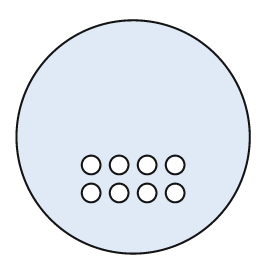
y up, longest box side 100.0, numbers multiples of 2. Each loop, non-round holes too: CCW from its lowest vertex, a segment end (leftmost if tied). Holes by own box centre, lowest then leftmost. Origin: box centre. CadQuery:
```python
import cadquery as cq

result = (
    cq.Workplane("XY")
    .moveTo(0.0, 0.0)
    .circle(50.0)
    .moveTo(-18.0, -24.0)
    .circle(4.0)
    .moveTo(-6.0, -24.0)
    .circle(4.0)
    .moveTo(6.0, -24.0)
    .circle(4.0)
    .moveTo(18.0, -24.0)
    .circle(4.0)
    .moveTo(-18.0, -12.0)
    .circle(4.0)
    .moveTo(-6.0, -12.0)
    .circle(4.0)
    .moveTo(6.0, -12.0)
    .circle(4.0)
    .moveTo(18.0, -12.0)
    .circle(4.0)
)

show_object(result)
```